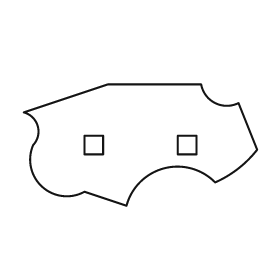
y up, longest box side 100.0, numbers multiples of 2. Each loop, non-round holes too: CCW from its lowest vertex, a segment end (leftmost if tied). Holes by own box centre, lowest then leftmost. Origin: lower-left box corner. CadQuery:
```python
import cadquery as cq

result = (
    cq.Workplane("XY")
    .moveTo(44.0, 0.0)
    .threePointArc((60.0, 16.0), (82.0, 10.0))
    .threePointArc((92.0, 16.0), (100.0, 24.0))
    .lineTo(92.0, 44.0)
    .threePointArc((82.0, 44.0), (76.0, 52.0))
    .lineTo(36.0, 52.0)
    .lineTo(0.0, 40.0)
    .threePointArc((6.0, 34.0), (4.0, 26.0))
    .threePointArc((8.0, 8.0), (26.0, 6.0))
    .close()
    .moveTo(26.0, 22.0)
    .lineTo(34.0, 22.0)
    .lineTo(34.0, 30.0)
    .lineTo(26.0, 30.0)
    .close()
    .moveTo(66.0, 22.0)
    .lineTo(74.0, 22.0)
    .lineTo(74.0, 30.0)
    .lineTo(66.0, 30.0)
    .close()
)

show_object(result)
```